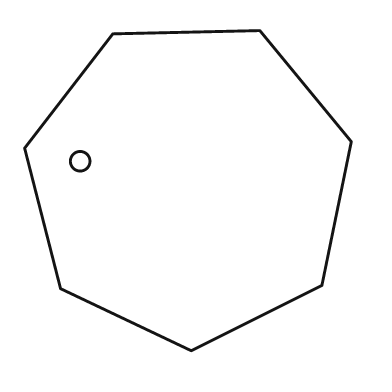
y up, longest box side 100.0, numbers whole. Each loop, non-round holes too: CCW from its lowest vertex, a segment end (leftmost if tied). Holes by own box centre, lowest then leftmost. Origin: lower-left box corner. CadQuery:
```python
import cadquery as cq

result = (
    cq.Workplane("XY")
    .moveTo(51.0, 0.0)
    .lineTo(91.0, 20.0)
    .lineTo(100.0, 64.0)
    .lineTo(72.0, 98.0)
    .lineTo(27.0, 97.0)
    .lineTo(0.0, 62.0)
    .lineTo(11.0, 19.0)
    .close()
    .moveTo(17.0, 58.0)
    .circle(3.0)
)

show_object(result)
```